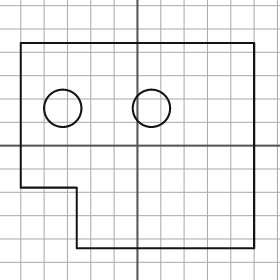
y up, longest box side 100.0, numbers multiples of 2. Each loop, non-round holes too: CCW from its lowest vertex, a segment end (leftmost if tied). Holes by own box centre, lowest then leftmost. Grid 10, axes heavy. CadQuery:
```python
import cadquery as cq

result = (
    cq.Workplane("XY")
    .moveTo(-26.0, -44.0)
    .lineTo(50.0, -44.0)
    .lineTo(50.0, 44.0)
    .lineTo(-50.0, 44.0)
    .lineTo(-50.0, -18.0)
    .lineTo(-26.0, -18.0)
    .close()
    .moveTo(-32.0, 16.0)
    .circle(8.0)
    .moveTo(6.0, 16.0)
    .circle(8.0)
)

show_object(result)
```